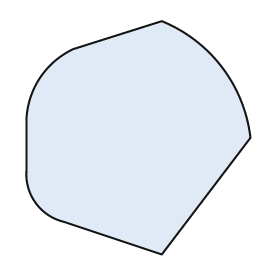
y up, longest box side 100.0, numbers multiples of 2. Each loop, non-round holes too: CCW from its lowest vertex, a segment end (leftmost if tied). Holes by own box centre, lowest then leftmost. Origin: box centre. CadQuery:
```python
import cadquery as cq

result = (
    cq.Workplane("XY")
    .moveTo(10.0, -50.0)
    .lineTo(48.0, 0.0)
    .threePointArc((36.0, 30.0), (10.0, 50.0))
    .lineTo(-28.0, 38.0)
    .threePointArc((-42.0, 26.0), (-48.0, 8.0))
    .lineTo(-48.0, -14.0)
    .threePointArc((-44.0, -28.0), (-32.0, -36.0))
    .close()
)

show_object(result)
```